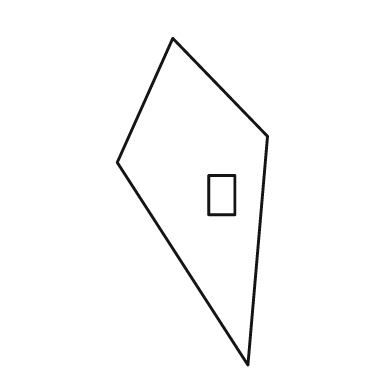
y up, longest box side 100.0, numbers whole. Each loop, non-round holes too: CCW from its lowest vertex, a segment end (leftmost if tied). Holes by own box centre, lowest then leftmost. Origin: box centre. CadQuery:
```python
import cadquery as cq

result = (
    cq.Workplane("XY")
    .moveTo(17.0, -50.0)
    .lineTo(23.0, 20.0)
    .lineTo(-6.0, 50.0)
    .lineTo(-23.0, 12.0)
    .close()
    .moveTo(5.0, -4.0)
    .lineTo(13.0, -4.0)
    .lineTo(13.0, 8.0)
    .lineTo(5.0, 8.0)
    .close()
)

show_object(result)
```